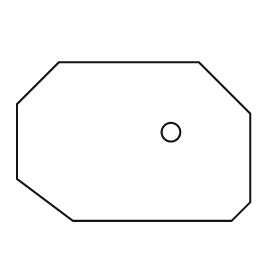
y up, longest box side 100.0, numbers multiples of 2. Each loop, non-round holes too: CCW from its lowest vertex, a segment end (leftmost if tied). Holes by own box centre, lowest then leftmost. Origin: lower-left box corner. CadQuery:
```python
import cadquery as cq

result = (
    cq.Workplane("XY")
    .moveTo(24.0, 0.0)
    .lineTo(92.0, 0.0)
    .lineTo(100.0, 8.0)
    .lineTo(100.0, 46.0)
    .lineTo(78.0, 68.0)
    .lineTo(18.0, 68.0)
    .lineTo(0.0, 50.0)
    .lineTo(0.0, 18.0)
    .close()
    .moveTo(66.0, 38.0)
    .circle(4.0)
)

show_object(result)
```